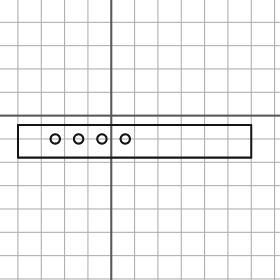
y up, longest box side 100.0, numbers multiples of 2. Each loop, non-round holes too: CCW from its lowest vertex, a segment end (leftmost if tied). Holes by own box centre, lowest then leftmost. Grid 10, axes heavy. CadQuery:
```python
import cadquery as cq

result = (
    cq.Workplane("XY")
    .moveTo(-40.0, -18.0)
    .lineTo(60.0, -18.0)
    .lineTo(60.0, -4.0)
    .lineTo(-40.0, -4.0)
    .close()
    .moveTo(-24.0, -10.0)
    .circle(2.0)
    .moveTo(-14.0, -10.0)
    .circle(2.0)
    .moveTo(-4.0, -10.0)
    .circle(2.0)
    .moveTo(6.0, -10.0)
    .circle(2.0)
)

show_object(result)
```